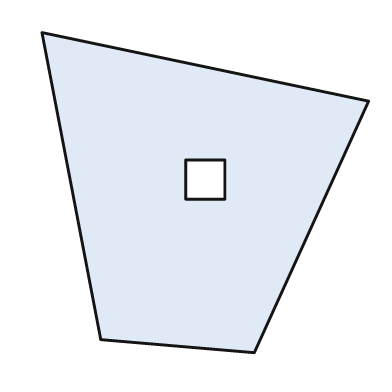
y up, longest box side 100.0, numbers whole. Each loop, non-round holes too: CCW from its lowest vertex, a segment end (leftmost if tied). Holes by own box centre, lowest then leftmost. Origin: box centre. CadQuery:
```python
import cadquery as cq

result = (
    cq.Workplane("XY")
    .moveTo(15.0, -49.0)
    .lineTo(50.0, 28.0)
    .lineTo(-50.0, 49.0)
    .lineTo(-32.0, -45.0)
    .close()
    .moveTo(-6.0, -2.0)
    .lineTo(6.0, -2.0)
    .lineTo(6.0, 10.0)
    .lineTo(-6.0, 10.0)
    .close()
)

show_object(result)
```